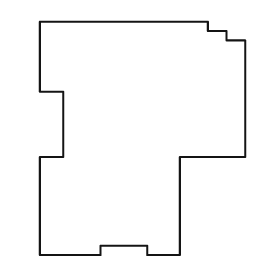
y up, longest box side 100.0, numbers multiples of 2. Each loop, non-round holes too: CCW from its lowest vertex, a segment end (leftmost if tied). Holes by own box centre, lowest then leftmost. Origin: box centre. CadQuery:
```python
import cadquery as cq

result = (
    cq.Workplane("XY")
    .moveTo(-44.0, -50.0)
    .lineTo(-18.0, -50.0)
    .lineTo(-18.0, -46.0)
    .lineTo(2.0, -46.0)
    .lineTo(2.0, -50.0)
    .lineTo(16.0, -50.0)
    .lineTo(16.0, -8.0)
    .lineTo(44.0, -8.0)
    .lineTo(44.0, 42.0)
    .lineTo(36.0, 42.0)
    .lineTo(36.0, 46.0)
    .lineTo(28.0, 46.0)
    .lineTo(28.0, 50.0)
    .lineTo(-44.0, 50.0)
    .lineTo(-44.0, 20.0)
    .lineTo(-34.0, 20.0)
    .lineTo(-34.0, -8.0)
    .lineTo(-44.0, -8.0)
    .close()
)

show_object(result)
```